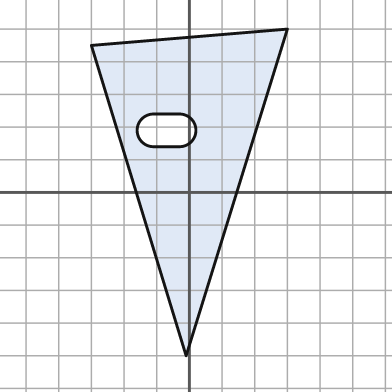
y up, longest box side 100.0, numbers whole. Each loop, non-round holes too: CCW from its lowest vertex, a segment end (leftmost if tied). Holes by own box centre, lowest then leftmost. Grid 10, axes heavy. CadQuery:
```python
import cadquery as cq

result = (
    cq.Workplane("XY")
    .moveTo(-1.0, -50.0)
    .lineTo(30.0, 50.0)
    .lineTo(-30.0, 45.0)
    .close()
    .moveTo(-11.0, 14.0)
    .lineTo(-3.0, 14.0)
    .threePointArc((2.0, 19.0), (-3.0, 24.0))
    .lineTo(-11.0, 24.0)
    .threePointArc((-16.0, 19.0), (-11.0, 14.0))
    .close()
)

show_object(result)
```